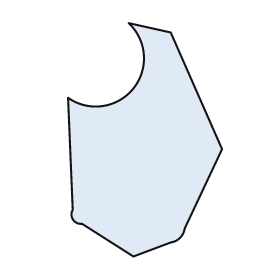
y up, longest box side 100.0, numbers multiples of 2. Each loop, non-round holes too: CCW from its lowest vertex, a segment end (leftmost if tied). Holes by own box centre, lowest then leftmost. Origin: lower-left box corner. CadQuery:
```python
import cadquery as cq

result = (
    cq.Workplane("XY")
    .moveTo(28.0, 0.0)
    .lineTo(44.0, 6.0)
    .threePointArc((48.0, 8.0), (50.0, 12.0))
    .lineTo(66.0, 46.0)
    .lineTo(44.0, 96.0)
    .lineTo(26.0, 100.0)
    .threePointArc((28.0, 72.0), (0.0, 68.0))
    .lineTo(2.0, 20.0)
    .threePointArc((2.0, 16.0), (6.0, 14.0))
    .close()
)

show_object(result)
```